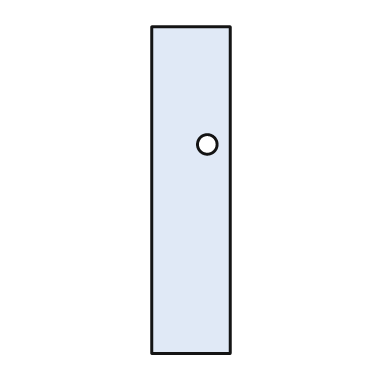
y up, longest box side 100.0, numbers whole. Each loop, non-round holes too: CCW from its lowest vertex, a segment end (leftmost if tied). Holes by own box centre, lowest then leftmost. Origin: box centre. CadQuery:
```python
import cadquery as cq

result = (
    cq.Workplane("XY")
    .moveTo(-12.0, -50.0)
    .lineTo(12.0, -50.0)
    .lineTo(12.0, 50.0)
    .lineTo(-12.0, 50.0)
    .close()
    .moveTo(5.0, 14.0)
    .circle(3.0)
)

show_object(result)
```